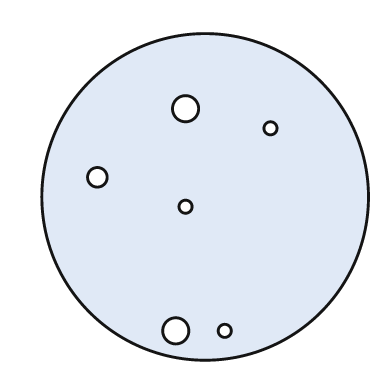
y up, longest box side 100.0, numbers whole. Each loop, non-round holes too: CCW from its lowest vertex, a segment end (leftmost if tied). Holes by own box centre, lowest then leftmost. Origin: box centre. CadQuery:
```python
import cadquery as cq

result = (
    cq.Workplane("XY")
    .moveTo(0.0, 0.0)
    .circle(50.0)
    .moveTo(-9.0, -41.0)
    .circle(4.0)
    .moveTo(6.0, -41.0)
    .circle(2.0)
    .moveTo(-6.0, -3.0)
    .circle(2.0)
    .moveTo(-33.0, 6.0)
    .circle(3.0)
    .moveTo(20.0, 21.0)
    .circle(2.0)
    .moveTo(-6.0, 27.0)
    .circle(4.0)
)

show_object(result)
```